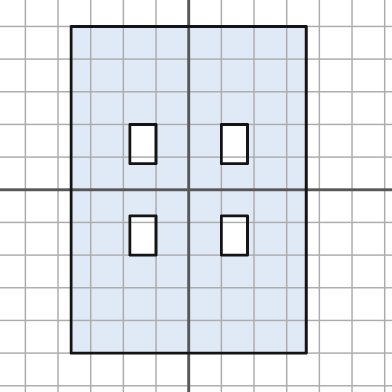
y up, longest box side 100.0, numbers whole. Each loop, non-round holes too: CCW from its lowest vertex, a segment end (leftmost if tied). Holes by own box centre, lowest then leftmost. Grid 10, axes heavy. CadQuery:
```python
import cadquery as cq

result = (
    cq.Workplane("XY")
    .moveTo(-36.0, -50.0)
    .lineTo(36.0, -50.0)
    .lineTo(36.0, 50.0)
    .lineTo(-36.0, 50.0)
    .close()
    .moveTo(-18.0, -20.0)
    .lineTo(-10.0, -20.0)
    .lineTo(-10.0, -8.0)
    .lineTo(-18.0, -8.0)
    .close()
    .moveTo(10.0, -20.0)
    .lineTo(18.0, -20.0)
    .lineTo(18.0, -8.0)
    .lineTo(10.0, -8.0)
    .close()
    .moveTo(-18.0, 8.0)
    .lineTo(-10.0, 8.0)
    .lineTo(-10.0, 20.0)
    .lineTo(-18.0, 20.0)
    .close()
    .moveTo(10.0, 8.0)
    .lineTo(18.0, 8.0)
    .lineTo(18.0, 20.0)
    .lineTo(10.0, 20.0)
    .close()
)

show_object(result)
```